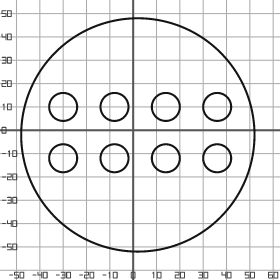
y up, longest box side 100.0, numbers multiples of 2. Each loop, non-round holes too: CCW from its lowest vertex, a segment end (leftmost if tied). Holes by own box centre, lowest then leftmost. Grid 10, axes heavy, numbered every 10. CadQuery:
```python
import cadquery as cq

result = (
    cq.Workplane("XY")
    .moveTo(2.0, -2.0)
    .circle(50.0)
    .moveTo(-30.0, -12.0)
    .circle(6.0)
    .moveTo(-8.0, -12.0)
    .circle(6.0)
    .moveTo(14.0, -12.0)
    .circle(6.0)
    .moveTo(36.0, -12.0)
    .circle(6.0)
    .moveTo(-30.0, 10.0)
    .circle(6.0)
    .moveTo(-8.0, 10.0)
    .circle(6.0)
    .moveTo(14.0, 10.0)
    .circle(6.0)
    .moveTo(36.0, 10.0)
    .circle(6.0)
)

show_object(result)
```